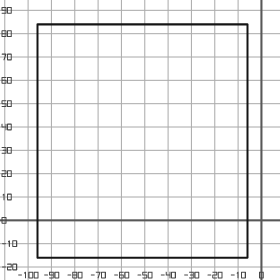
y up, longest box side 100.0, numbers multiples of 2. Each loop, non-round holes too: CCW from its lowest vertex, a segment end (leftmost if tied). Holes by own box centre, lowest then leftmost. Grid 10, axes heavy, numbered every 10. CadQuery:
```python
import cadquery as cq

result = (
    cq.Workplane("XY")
    .moveTo(-96.0, -16.0)
    .lineTo(-6.0, -16.0)
    .lineTo(-6.0, 84.0)
    .lineTo(-96.0, 84.0)
    .close()
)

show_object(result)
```